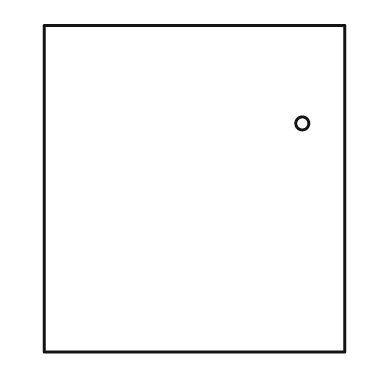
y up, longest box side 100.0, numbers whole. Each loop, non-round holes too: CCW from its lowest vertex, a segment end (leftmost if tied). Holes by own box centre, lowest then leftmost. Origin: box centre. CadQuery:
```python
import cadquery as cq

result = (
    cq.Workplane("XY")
    .moveTo(-46.0, -50.0)
    .lineTo(46.0, -50.0)
    .lineTo(46.0, 50.0)
    .lineTo(-46.0, 50.0)
    .close()
    .moveTo(33.0, 20.0)
    .circle(2.0)
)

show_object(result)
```